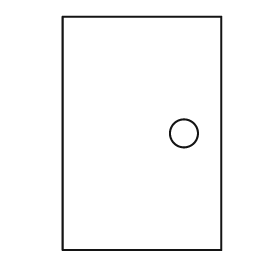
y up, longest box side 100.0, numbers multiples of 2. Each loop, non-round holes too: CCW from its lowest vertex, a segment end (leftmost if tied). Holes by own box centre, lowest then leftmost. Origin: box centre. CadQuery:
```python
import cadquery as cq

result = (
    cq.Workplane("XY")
    .moveTo(-34.0, -50.0)
    .lineTo(34.0, -50.0)
    .lineTo(34.0, 50.0)
    .lineTo(-34.0, 50.0)
    .close()
    .moveTo(18.0, 0.0)
    .circle(6.0)
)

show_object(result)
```